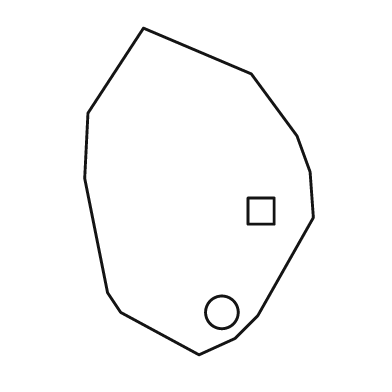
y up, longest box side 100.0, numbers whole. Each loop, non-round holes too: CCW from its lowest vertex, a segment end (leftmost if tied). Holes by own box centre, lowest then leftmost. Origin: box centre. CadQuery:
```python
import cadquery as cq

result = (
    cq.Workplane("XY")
    .moveTo(0.0, -50.0)
    .lineTo(11.0, -45.0)
    .lineTo(18.0, -38.0)
    .lineTo(35.0, -8.0)
    .lineTo(34.0, 6.0)
    .lineTo(30.0, 17.0)
    .lineTo(16.0, 36.0)
    .lineTo(-17.0, 50.0)
    .lineTo(-34.0, 24.0)
    .lineTo(-35.0, 4.0)
    .lineTo(-28.0, -31.0)
    .lineTo(-24.0, -37.0)
    .close()
    .moveTo(7.0, -37.0)
    .circle(5.0)
    .moveTo(15.0, -10.0)
    .lineTo(23.0, -10.0)
    .lineTo(23.0, -2.0)
    .lineTo(15.0, -2.0)
    .close()
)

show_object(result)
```